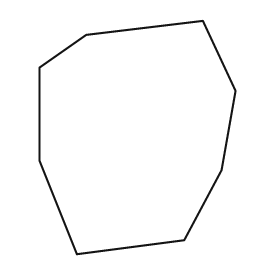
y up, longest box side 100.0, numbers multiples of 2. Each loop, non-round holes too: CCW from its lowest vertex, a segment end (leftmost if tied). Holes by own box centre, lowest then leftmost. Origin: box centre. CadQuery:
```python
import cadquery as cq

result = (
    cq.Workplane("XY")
    .moveTo(-26.0, -50.0)
    .lineTo(20.0, -44.0)
    .lineTo(36.0, -14.0)
    .lineTo(42.0, 20.0)
    .lineTo(28.0, 50.0)
    .lineTo(-22.0, 44.0)
    .lineTo(-42.0, 30.0)
    .lineTo(-42.0, -10.0)
    .close()
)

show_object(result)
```